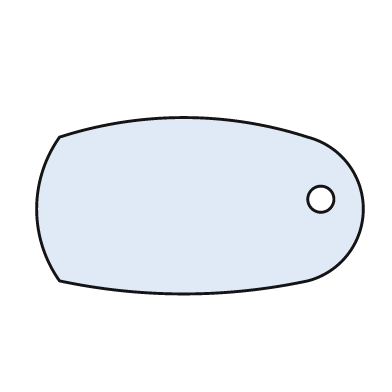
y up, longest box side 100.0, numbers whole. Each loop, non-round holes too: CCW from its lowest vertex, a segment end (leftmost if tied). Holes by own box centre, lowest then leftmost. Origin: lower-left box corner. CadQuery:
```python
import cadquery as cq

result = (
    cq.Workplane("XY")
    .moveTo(7.0, 4.0)
    .threePointArc((45.0, 0.0), (83.0, 4.0))
    .threePointArc((100.0, 26.0), (83.0, 48.0))
    .threePointArc((45.0, 54.0), (7.0, 48.0))
    .threePointArc((0.0, 26.0), (7.0, 4.0))
    .close()
    .moveTo(87.0, 29.0)
    .circle(4.0)
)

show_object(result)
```